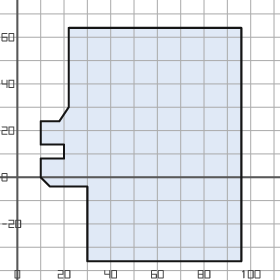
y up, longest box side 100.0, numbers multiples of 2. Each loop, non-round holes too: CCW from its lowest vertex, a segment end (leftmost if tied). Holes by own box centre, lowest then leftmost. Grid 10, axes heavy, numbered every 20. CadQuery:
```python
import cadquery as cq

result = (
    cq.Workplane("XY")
    .moveTo(30.0, -36.0)
    .lineTo(96.0, -36.0)
    .lineTo(96.0, 64.0)
    .lineTo(22.0, 64.0)
    .lineTo(22.0, 30.0)
    .lineTo(18.0, 24.0)
    .lineTo(10.0, 24.0)
    .lineTo(10.0, 14.0)
    .lineTo(20.0, 14.0)
    .lineTo(20.0, 8.0)
    .lineTo(10.0, 8.0)
    .lineTo(10.0, 0.0)
    .lineTo(14.0, -4.0)
    .lineTo(30.0, -4.0)
    .close()
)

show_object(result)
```